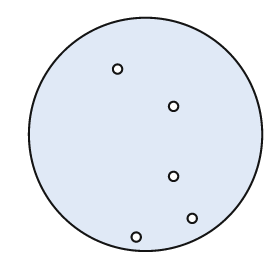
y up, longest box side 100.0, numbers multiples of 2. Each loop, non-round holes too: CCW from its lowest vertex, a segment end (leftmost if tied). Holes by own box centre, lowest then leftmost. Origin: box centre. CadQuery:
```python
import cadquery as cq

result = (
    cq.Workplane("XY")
    .moveTo(0.0, 0.0)
    .circle(50.0)
    .moveTo(-4.0, -44.0)
    .circle(2.0)
    .moveTo(20.0, -36.0)
    .circle(2.0)
    .moveTo(12.0, -18.0)
    .circle(2.0)
    .moveTo(12.0, 12.0)
    .circle(2.0)
    .moveTo(-12.0, 28.0)
    .circle(2.0)
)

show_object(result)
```